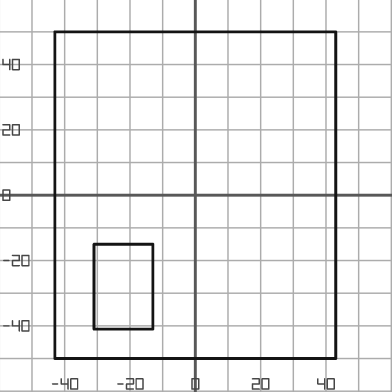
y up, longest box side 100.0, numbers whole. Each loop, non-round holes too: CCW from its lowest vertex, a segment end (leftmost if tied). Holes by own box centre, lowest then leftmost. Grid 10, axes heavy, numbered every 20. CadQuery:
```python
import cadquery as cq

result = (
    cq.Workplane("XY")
    .moveTo(-43.0, -50.0)
    .lineTo(43.0, -50.0)
    .lineTo(43.0, 50.0)
    .lineTo(-43.0, 50.0)
    .close()
    .moveTo(-31.0, -41.0)
    .lineTo(-13.0, -41.0)
    .lineTo(-13.0, -15.0)
    .lineTo(-31.0, -15.0)
    .close()
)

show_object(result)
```